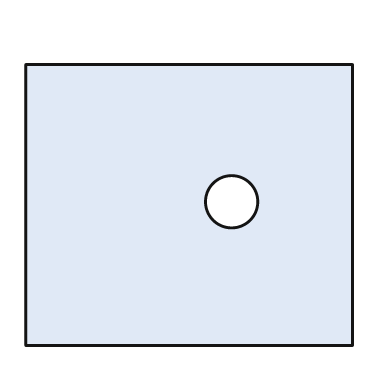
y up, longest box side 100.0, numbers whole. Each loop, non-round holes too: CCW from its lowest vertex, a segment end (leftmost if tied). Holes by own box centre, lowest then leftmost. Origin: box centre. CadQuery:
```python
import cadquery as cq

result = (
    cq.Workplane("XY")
    .moveTo(-50.0, -43.0)
    .lineTo(50.0, -43.0)
    .lineTo(50.0, 43.0)
    .lineTo(-50.0, 43.0)
    .close()
    .moveTo(13.0, 1.0)
    .circle(8.0)
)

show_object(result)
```